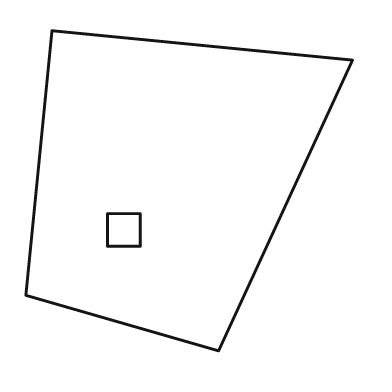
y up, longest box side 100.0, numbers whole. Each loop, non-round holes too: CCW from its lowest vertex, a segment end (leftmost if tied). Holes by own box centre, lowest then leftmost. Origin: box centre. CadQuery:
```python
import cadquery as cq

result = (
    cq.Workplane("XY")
    .moveTo(9.0, -49.0)
    .lineTo(50.0, 40.0)
    .lineTo(-42.0, 49.0)
    .lineTo(-50.0, -32.0)
    .close()
    .moveTo(-25.0, -17.0)
    .lineTo(-15.0, -17.0)
    .lineTo(-15.0, -7.0)
    .lineTo(-25.0, -7.0)
    .close()
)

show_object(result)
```